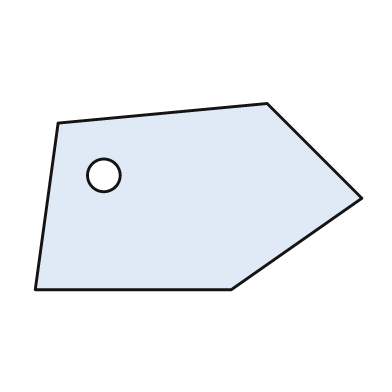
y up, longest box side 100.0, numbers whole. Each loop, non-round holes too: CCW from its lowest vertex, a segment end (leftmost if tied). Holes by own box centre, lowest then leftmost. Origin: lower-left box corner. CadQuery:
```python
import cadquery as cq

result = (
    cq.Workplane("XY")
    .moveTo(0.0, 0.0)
    .lineTo(60.0, 0.0)
    .lineTo(100.0, 28.0)
    .lineTo(71.0, 57.0)
    .lineTo(7.0, 51.0)
    .close()
    .moveTo(21.0, 35.0)
    .circle(5.0)
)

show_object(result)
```